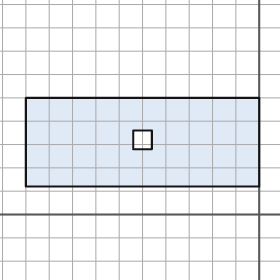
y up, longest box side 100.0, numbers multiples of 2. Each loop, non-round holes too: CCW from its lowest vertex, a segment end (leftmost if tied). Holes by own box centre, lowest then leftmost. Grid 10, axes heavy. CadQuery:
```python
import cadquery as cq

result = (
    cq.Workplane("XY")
    .moveTo(-100.0, 12.0)
    .lineTo(0.0, 12.0)
    .lineTo(0.0, 50.0)
    .lineTo(-100.0, 50.0)
    .close()
    .moveTo(-54.0, 28.0)
    .lineTo(-46.0, 28.0)
    .lineTo(-46.0, 36.0)
    .lineTo(-54.0, 36.0)
    .close()
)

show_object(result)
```